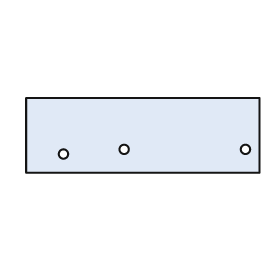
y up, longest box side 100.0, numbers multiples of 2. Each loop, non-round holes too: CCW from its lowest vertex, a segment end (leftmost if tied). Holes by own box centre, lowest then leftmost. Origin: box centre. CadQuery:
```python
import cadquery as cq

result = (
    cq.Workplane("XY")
    .moveTo(-50.0, -16.0)
    .lineTo(50.0, -16.0)
    .lineTo(50.0, 16.0)
    .lineTo(-50.0, 16.0)
    .close()
    .moveTo(-34.0, -8.0)
    .circle(2.0)
    .moveTo(-8.0, -6.0)
    .circle(2.0)
    .moveTo(44.0, -6.0)
    .circle(2.0)
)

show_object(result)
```